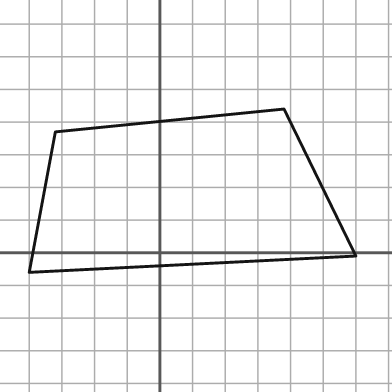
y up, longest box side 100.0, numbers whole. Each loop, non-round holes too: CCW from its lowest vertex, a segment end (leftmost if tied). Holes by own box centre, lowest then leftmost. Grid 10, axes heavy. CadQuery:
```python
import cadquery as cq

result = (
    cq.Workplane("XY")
    .moveTo(-40.0, -6.0)
    .lineTo(60.0, -1.0)
    .lineTo(38.0, 44.0)
    .lineTo(-32.0, 37.0)
    .close()
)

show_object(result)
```